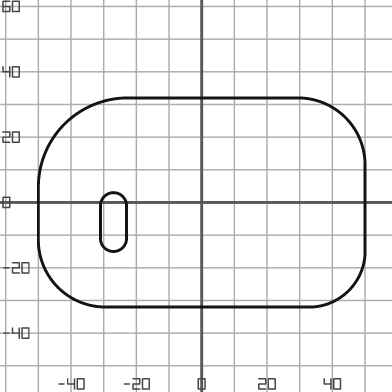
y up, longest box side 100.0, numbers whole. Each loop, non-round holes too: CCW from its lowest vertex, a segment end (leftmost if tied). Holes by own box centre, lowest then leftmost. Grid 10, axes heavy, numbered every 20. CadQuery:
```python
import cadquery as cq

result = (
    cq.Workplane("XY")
    .moveTo(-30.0, -32.0)
    .lineTo(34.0, -32.0)
    .threePointArc((45.0, -27.0), (50.0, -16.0))
    .lineTo(50.0, 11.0)
    .threePointArc((44.0, 26.0), (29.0, 32.0))
    .lineTo(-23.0, 32.0)
    .threePointArc((-42.0, 24.0), (-50.0, 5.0))
    .lineTo(-50.0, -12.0)
    .threePointArc((-44.0, -26.0), (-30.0, -32.0))
    .close()
    .moveTo(-31.0, -11.0)
    .threePointArc((-27.0, -15.0), (-23.0, -11.0))
    .lineTo(-23.0, -1.0)
    .threePointArc((-27.0, 3.0), (-31.0, -1.0))
    .close()
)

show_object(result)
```